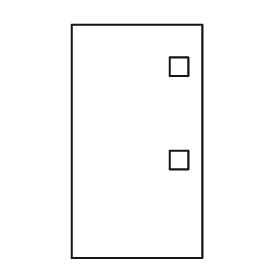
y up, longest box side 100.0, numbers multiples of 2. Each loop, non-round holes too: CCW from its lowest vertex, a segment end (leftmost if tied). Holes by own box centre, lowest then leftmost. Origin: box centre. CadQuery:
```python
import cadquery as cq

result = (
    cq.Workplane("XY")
    .moveTo(-28.0, -50.0)
    .lineTo(28.0, -50.0)
    .lineTo(28.0, 50.0)
    .lineTo(-28.0, 50.0)
    .close()
    .moveTo(14.0, -12.0)
    .lineTo(22.0, -12.0)
    .lineTo(22.0, -4.0)
    .lineTo(14.0, -4.0)
    .close()
    .moveTo(14.0, 28.0)
    .lineTo(22.0, 28.0)
    .lineTo(22.0, 36.0)
    .lineTo(14.0, 36.0)
    .close()
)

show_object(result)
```